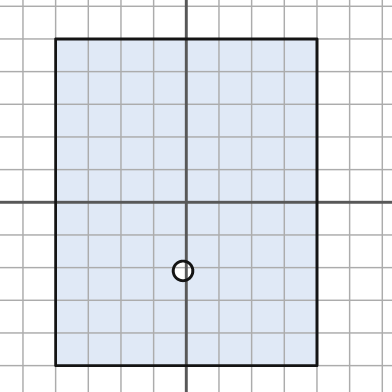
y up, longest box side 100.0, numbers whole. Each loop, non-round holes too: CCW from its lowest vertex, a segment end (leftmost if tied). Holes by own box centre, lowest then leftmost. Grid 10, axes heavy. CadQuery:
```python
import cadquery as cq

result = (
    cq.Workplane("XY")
    .moveTo(-40.0, -50.0)
    .lineTo(40.0, -50.0)
    .lineTo(40.0, 50.0)
    .lineTo(-40.0, 50.0)
    .close()
    .moveTo(-1.0, -21.0)
    .circle(3.0)
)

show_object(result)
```